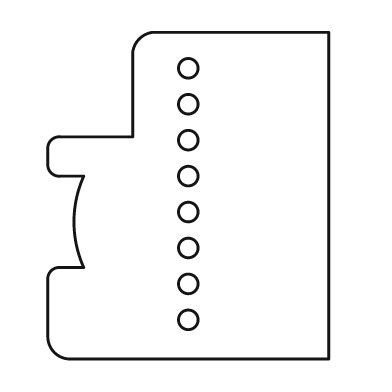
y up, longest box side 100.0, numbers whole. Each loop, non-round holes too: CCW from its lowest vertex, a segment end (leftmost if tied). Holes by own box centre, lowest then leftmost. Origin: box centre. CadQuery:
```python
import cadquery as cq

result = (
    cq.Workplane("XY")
    .moveTo(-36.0, -50.0)
    .lineTo(43.0, -50.0)
    .lineTo(43.0, 50.0)
    .lineTo(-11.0, 50.0)
    .threePointArc((-15.0, 48.0), (-17.0, 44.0))
    .lineTo(-17.0, 18.0)
    .lineTo(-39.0, 18.0)
    .threePointArc((-42.0, 17.0), (-43.0, 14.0))
    .lineTo(-43.0, 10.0)
    .threePointArc((-42.0, 7.0), (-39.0, 6.0))
    .lineTo(-32.0, 6.0)
    .threePointArc((-35.0, -8.0), (-32.0, -22.0))
    .lineTo(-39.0, -22.0)
    .threePointArc((-42.0, -23.0), (-43.0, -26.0))
    .lineTo(-43.0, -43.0)
    .threePointArc((-41.0, -48.0), (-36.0, -50.0))
    .close()
    .moveTo(0.0, -38.0)
    .circle(3.0)
    .moveTo(0.0, -27.0)
    .circle(3.0)
    .moveTo(0.0, -16.0)
    .circle(3.0)
    .moveTo(0.0, -5.0)
    .circle(3.0)
    .moveTo(0.0, 6.0)
    .circle(3.0)
    .moveTo(0.0, 17.0)
    .circle(3.0)
    .moveTo(0.0, 28.0)
    .circle(3.0)
    .moveTo(0.0, 39.0)
    .circle(3.0)
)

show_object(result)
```